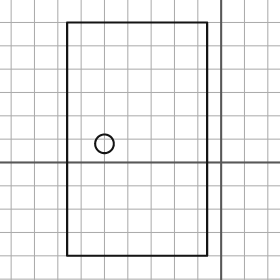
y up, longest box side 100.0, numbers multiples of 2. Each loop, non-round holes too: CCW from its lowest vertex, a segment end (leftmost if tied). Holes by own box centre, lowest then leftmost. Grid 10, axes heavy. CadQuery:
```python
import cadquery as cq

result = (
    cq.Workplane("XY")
    .moveTo(-66.0, -40.0)
    .lineTo(-6.0, -40.0)
    .lineTo(-6.0, 60.0)
    .lineTo(-66.0, 60.0)
    .close()
    .moveTo(-50.0, 8.0)
    .circle(4.0)
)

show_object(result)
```